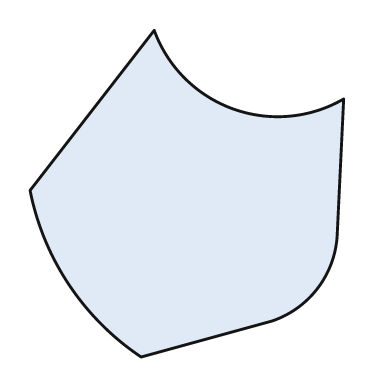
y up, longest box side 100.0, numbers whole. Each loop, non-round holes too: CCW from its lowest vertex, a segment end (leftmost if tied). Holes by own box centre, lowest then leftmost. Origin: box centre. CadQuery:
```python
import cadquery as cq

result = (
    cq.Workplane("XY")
    .moveTo(-14.0, -50.0)
    .lineTo(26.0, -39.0)
    .threePointArc((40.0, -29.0), (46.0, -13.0))
    .lineTo(48.0, 29.0)
    .threePointArc((14.0, 26.0), (-10.0, 50.0))
    .lineTo(-48.0, 1.0)
    .threePointArc((-36.0, -28.0), (-14.0, -50.0))
    .close()
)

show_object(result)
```